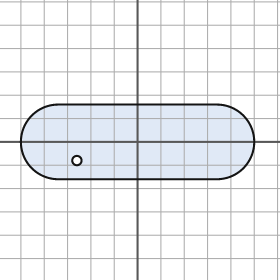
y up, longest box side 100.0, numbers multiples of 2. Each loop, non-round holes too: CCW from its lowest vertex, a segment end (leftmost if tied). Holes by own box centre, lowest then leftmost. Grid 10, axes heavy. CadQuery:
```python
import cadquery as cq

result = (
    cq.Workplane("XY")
    .moveTo(-34.0, -16.0)
    .lineTo(34.0, -16.0)
    .threePointArc((50.0, 0.0), (34.0, 16.0))
    .lineTo(-34.0, 16.0)
    .threePointArc((-50.0, 0.0), (-34.0, -16.0))
    .close()
    .moveTo(-26.0, -8.0)
    .circle(2.0)
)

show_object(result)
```